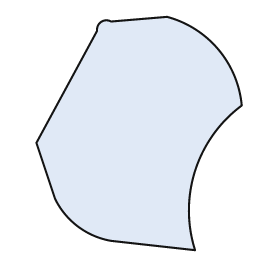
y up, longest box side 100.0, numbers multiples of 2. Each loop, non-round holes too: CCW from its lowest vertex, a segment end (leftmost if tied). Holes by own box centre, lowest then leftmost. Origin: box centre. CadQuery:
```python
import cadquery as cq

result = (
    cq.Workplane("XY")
    .moveTo(24.0, -50.0)
    .threePointArc((24.0, -16.0), (44.0, 12.0))
    .threePointArc((34.0, 36.0), (12.0, 50.0))
    .lineTo(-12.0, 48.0)
    .threePointArc((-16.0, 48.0), (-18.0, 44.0))
    .lineTo(-44.0, -4.0)
    .lineTo(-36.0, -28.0)
    .threePointArc((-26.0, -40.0), (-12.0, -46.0))
    .close()
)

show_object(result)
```